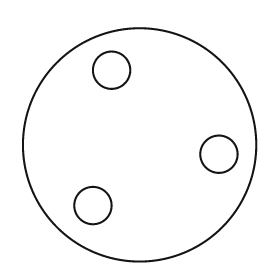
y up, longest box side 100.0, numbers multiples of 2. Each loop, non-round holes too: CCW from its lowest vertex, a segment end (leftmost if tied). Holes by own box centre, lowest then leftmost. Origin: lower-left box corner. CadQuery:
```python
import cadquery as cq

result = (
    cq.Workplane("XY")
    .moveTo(50.0, 50.0)
    .circle(50.0)
    .moveTo(30.0, 24.0)
    .circle(8.0)
    .moveTo(84.0, 46.0)
    .circle(8.0)
    .moveTo(38.0, 82.0)
    .circle(8.0)
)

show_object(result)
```